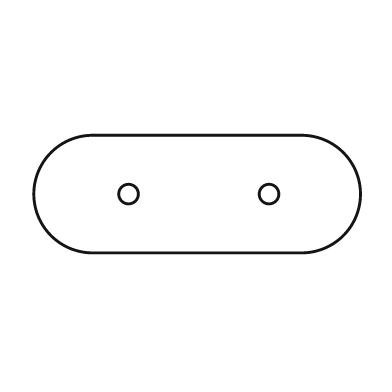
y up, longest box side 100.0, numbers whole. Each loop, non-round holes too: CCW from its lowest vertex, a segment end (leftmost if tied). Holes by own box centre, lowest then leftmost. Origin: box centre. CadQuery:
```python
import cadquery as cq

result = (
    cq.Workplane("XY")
    .moveTo(-32.0, -18.0)
    .lineTo(32.0, -18.0)
    .threePointArc((50.0, 0.0), (32.0, 18.0))
    .lineTo(-32.0, 18.0)
    .threePointArc((-50.0, 0.0), (-32.0, -18.0))
    .close()
    .moveTo(-21.0, 0.0)
    .circle(3.0)
    .moveTo(22.0, 0.0)
    .circle(3.0)
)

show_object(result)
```